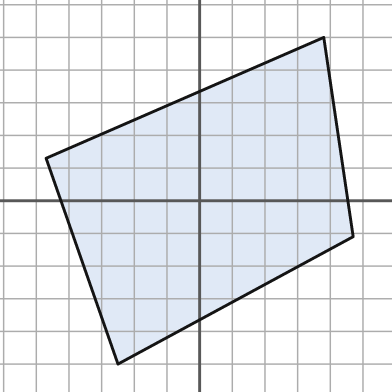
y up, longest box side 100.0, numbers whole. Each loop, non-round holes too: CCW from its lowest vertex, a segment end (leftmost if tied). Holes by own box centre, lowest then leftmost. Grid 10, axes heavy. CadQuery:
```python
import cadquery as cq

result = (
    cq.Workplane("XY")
    .moveTo(-25.0, -50.0)
    .lineTo(47.0, -11.0)
    .lineTo(38.0, 50.0)
    .lineTo(-47.0, 13.0)
    .close()
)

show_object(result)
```